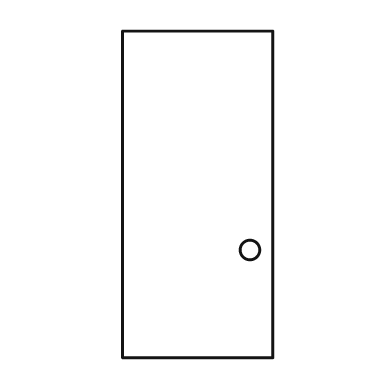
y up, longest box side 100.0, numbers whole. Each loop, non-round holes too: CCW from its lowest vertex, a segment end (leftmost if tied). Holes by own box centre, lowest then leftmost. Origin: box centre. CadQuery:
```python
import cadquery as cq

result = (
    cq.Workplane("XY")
    .moveTo(-23.0, -50.0)
    .lineTo(23.0, -50.0)
    .lineTo(23.0, 50.0)
    .lineTo(-23.0, 50.0)
    .close()
    .moveTo(16.0, -17.0)
    .circle(3.0)
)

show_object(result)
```